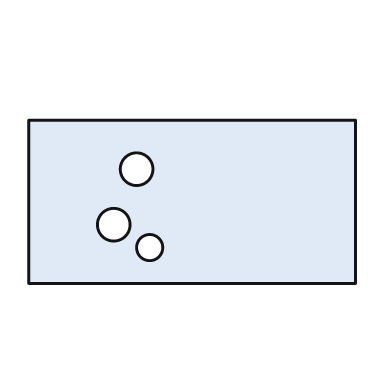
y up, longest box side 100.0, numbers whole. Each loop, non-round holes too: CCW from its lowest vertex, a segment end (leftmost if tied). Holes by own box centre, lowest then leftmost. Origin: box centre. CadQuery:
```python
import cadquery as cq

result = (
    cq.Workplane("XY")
    .moveTo(-50.0, -25.0)
    .lineTo(50.0, -25.0)
    .lineTo(50.0, 25.0)
    .lineTo(-50.0, 25.0)
    .close()
    .moveTo(-13.0, -14.0)
    .circle(4.0)
    .moveTo(-24.0, -7.0)
    .circle(5.0)
    .moveTo(-17.0, 10.0)
    .circle(5.0)
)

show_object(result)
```